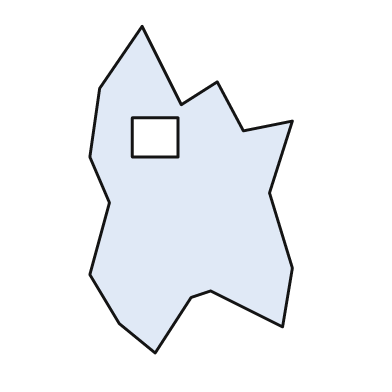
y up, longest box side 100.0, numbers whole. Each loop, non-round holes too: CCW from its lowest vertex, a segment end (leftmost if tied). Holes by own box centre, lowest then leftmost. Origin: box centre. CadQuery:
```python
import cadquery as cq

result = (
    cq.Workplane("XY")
    .moveTo(-11.0, -50.0)
    .lineTo(0.0, -33.0)
    .lineTo(6.0, -31.0)
    .lineTo(28.0, -42.0)
    .lineTo(31.0, -24.0)
    .lineTo(24.0, -1.0)
    .lineTo(31.0, 21.0)
    .lineTo(16.0, 18.0)
    .lineTo(8.0, 33.0)
    .lineTo(-3.0, 26.0)
    .lineTo(-15.0, 50.0)
    .lineTo(-28.0, 31.0)
    .lineTo(-31.0, 10.0)
    .lineTo(-25.0, -4.0)
    .lineTo(-31.0, -26.0)
    .lineTo(-22.0, -41.0)
    .close()
    .moveTo(-18.0, 10.0)
    .lineTo(-4.0, 10.0)
    .lineTo(-4.0, 22.0)
    .lineTo(-18.0, 22.0)
    .close()
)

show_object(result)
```